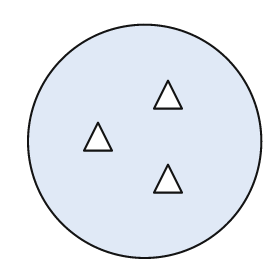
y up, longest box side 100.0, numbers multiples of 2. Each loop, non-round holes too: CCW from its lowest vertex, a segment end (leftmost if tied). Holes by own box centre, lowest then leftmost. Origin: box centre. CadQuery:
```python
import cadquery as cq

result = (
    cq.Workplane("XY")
    .moveTo(0.0, 0.0)
    .circle(50.0)
    .moveTo(4.0, -22.0)
    .lineTo(16.0, -22.0)
    .lineTo(10.0, -10.0)
    .close()
    .moveTo(-26.0, -4.0)
    .lineTo(-14.0, -4.0)
    .lineTo(-20.0, 8.0)
    .close()
    .moveTo(4.0, 14.0)
    .lineTo(16.0, 14.0)
    .lineTo(10.0, 26.0)
    .close()
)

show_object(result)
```